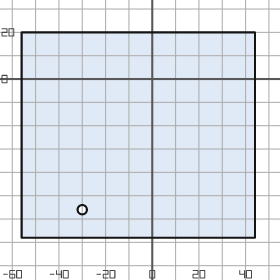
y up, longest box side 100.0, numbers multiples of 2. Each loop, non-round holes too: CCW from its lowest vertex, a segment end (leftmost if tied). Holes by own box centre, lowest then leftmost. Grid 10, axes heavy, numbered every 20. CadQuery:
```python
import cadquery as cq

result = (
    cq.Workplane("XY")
    .moveTo(-56.0, -68.0)
    .lineTo(44.0, -68.0)
    .lineTo(44.0, 20.0)
    .lineTo(-56.0, 20.0)
    .close()
    .moveTo(-30.0, -56.0)
    .circle(2.0)
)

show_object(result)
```